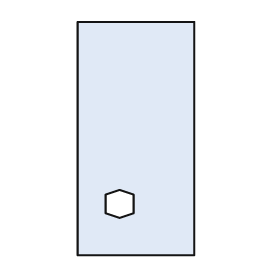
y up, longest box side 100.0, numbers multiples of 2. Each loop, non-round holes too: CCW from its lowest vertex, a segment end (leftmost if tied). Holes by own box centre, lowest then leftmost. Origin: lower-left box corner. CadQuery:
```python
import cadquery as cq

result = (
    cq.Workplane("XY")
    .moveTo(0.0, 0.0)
    .lineTo(50.0, 0.0)
    .lineTo(50.0, 100.0)
    .lineTo(0.0, 100.0)
    .close()
    .moveTo(18.0, 16.0)
    .lineTo(24.0, 18.0)
    .lineTo(24.0, 26.0)
    .lineTo(18.0, 28.0)
    .lineTo(12.0, 26.0)
    .lineTo(12.0, 18.0)
    .close()
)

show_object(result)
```